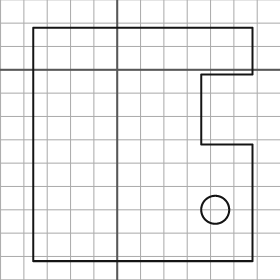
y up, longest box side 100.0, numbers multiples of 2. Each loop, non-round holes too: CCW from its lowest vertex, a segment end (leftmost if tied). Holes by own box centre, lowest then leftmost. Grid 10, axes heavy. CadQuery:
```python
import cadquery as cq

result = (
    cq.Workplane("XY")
    .moveTo(-36.0, -82.0)
    .lineTo(58.0, -82.0)
    .lineTo(58.0, -32.0)
    .lineTo(36.0, -32.0)
    .lineTo(36.0, -2.0)
    .lineTo(58.0, -2.0)
    .lineTo(58.0, 18.0)
    .lineTo(-36.0, 18.0)
    .close()
    .moveTo(42.0, -60.0)
    .circle(6.0)
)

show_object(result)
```